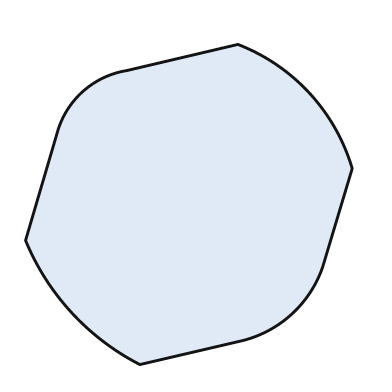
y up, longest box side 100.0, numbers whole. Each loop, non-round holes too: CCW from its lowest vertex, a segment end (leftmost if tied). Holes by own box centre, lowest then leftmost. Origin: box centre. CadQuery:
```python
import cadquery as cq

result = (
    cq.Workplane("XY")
    .moveTo(-15.0, -49.0)
    .lineTo(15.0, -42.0)
    .threePointArc((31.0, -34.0), (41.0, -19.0))
    .lineTo(50.0, 11.0)
    .threePointArc((37.0, 34.0), (15.0, 49.0))
    .lineTo(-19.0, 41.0)
    .threePointArc((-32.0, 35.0), (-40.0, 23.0))
    .lineTo(-50.0, -11.0)
    .threePointArc((-36.0, -33.0), (-15.0, -49.0))
    .close()
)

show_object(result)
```